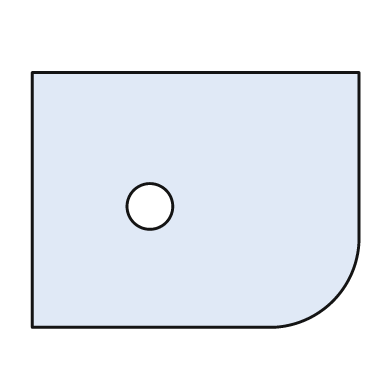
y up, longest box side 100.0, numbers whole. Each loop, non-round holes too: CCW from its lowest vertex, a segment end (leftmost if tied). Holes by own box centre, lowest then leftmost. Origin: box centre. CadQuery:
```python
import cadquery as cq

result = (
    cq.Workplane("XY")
    .moveTo(-50.0, -39.0)
    .lineTo(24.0, -39.0)
    .threePointArc((42.0, -31.0), (50.0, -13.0))
    .lineTo(50.0, 39.0)
    .lineTo(-50.0, 39.0)
    .close()
    .moveTo(-14.0, -2.0)
    .circle(7.0)
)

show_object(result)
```